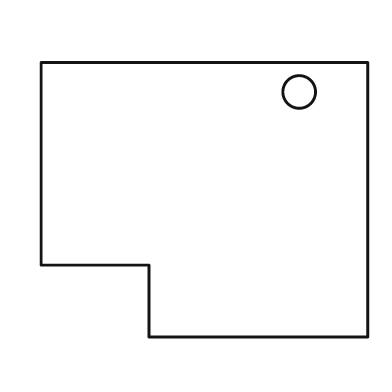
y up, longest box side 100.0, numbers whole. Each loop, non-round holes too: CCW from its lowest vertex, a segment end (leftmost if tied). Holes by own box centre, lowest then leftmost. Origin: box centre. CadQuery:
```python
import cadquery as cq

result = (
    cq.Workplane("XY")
    .moveTo(-17.0, -42.0)
    .lineTo(50.0, -42.0)
    .lineTo(50.0, 42.0)
    .lineTo(-50.0, 42.0)
    .lineTo(-50.0, -20.0)
    .lineTo(-17.0, -20.0)
    .close()
    .moveTo(29.0, 33.0)
    .circle(5.0)
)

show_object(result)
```